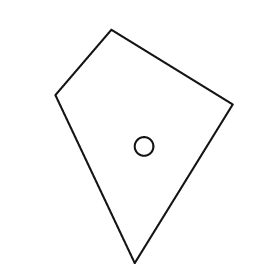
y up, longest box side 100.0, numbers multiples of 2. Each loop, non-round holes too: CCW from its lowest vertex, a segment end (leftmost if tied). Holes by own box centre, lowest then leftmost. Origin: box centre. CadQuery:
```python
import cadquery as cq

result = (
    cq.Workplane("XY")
    .moveTo(-4.0, -50.0)
    .lineTo(38.0, 18.0)
    .lineTo(-14.0, 50.0)
    .lineTo(-38.0, 22.0)
    .close()
    .moveTo(0.0, 0.0)
    .circle(4.0)
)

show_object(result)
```